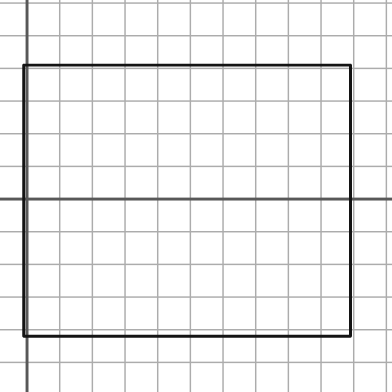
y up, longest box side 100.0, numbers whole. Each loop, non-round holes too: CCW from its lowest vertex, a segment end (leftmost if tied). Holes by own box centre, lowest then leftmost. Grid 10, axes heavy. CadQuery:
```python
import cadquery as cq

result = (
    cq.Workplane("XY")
    .moveTo(-1.0, -42.0)
    .lineTo(99.0, -42.0)
    .lineTo(99.0, 41.0)
    .lineTo(-1.0, 41.0)
    .close()
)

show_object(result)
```